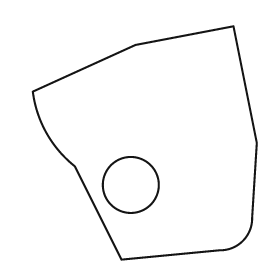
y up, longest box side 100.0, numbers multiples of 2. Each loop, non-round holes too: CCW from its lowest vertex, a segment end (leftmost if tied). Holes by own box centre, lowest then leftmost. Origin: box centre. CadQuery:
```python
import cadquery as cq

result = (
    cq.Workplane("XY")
    .moveTo(-10.0, -50.0)
    .lineTo(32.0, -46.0)
    .threePointArc((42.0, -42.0), (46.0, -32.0))
    .lineTo(48.0, 0.0)
    .lineTo(38.0, 50.0)
    .lineTo(-4.0, 42.0)
    .lineTo(-48.0, 22.0)
    .threePointArc((-42.0, 4.0), (-30.0, -10.0))
    .close()
    .moveTo(-6.0, -18.0)
    .circle(12.0)
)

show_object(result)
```